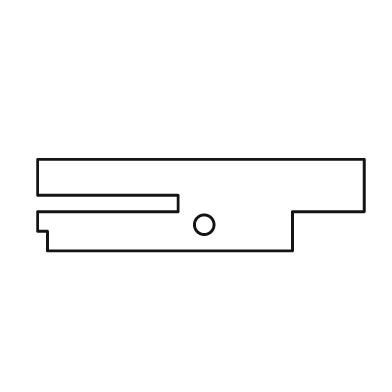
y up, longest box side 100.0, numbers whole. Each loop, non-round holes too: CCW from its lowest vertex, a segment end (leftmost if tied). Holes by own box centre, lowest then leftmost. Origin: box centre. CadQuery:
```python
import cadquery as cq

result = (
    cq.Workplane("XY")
    .moveTo(-47.0, -14.0)
    .lineTo(28.0, -14.0)
    .lineTo(28.0, -2.0)
    .lineTo(50.0, -2.0)
    .lineTo(50.0, 14.0)
    .lineTo(-50.0, 14.0)
    .lineTo(-50.0, 3.0)
    .lineTo(-7.0, 3.0)
    .lineTo(-7.0, -2.0)
    .lineTo(-50.0, -2.0)
    .lineTo(-50.0, -8.0)
    .lineTo(-47.0, -8.0)
    .close()
    .moveTo(1.0, -6.0)
    .circle(3.0)
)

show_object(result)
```